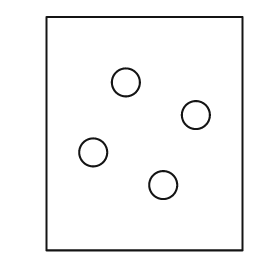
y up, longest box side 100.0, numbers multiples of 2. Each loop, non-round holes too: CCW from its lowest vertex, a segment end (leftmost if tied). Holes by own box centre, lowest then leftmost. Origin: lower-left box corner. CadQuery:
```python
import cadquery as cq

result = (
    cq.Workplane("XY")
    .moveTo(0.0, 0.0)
    .lineTo(84.0, 0.0)
    .lineTo(84.0, 100.0)
    .lineTo(0.0, 100.0)
    .close()
    .moveTo(50.0, 28.0)
    .circle(6.0)
    .moveTo(20.0, 42.0)
    .circle(6.0)
    .moveTo(64.0, 58.0)
    .circle(6.0)
    .moveTo(34.0, 72.0)
    .circle(6.0)
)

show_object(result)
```